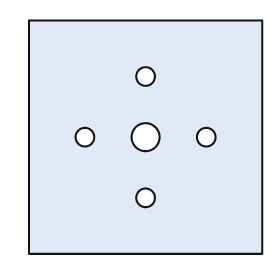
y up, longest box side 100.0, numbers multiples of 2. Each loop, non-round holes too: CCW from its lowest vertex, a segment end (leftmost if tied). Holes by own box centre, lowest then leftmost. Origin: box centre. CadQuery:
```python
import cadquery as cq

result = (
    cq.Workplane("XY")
    .moveTo(-50.0, -50.0)
    .lineTo(50.0, -50.0)
    .lineTo(50.0, 50.0)
    .lineTo(-50.0, 50.0)
    .close()
    .moveTo(0.0, -26.0)
    .circle(4.0)
    .moveTo(-26.0, 0.0)
    .circle(4.0)
    .moveTo(0.0, 0.0)
    .circle(6.0)
    .moveTo(26.0, 0.0)
    .circle(4.0)
    .moveTo(0.0, 26.0)
    .circle(4.0)
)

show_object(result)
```